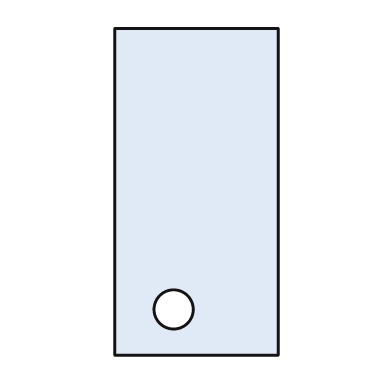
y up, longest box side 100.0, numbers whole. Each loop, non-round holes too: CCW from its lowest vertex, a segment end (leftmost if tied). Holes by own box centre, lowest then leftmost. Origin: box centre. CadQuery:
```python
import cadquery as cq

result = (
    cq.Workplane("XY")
    .moveTo(-25.0, -50.0)
    .lineTo(25.0, -50.0)
    .lineTo(25.0, 50.0)
    .lineTo(-25.0, 50.0)
    .close()
    .moveTo(-7.0, -36.0)
    .circle(6.0)
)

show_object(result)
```